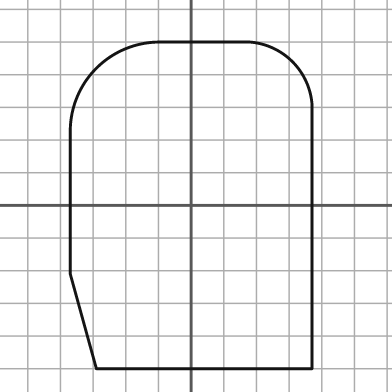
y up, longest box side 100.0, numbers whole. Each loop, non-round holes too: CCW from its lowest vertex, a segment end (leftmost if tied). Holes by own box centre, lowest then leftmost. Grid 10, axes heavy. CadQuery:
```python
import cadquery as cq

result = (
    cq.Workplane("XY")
    .moveTo(-29.0, -50.0)
    .lineTo(37.0, -50.0)
    .lineTo(37.0, 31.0)
    .threePointArc((31.0, 44.0), (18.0, 50.0))
    .lineTo(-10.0, 50.0)
    .threePointArc((-29.0, 42.0), (-37.0, 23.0))
    .lineTo(-37.0, -21.0)
    .close()
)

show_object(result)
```